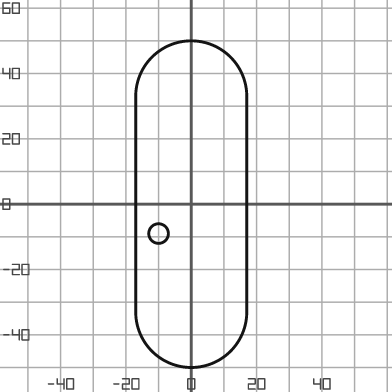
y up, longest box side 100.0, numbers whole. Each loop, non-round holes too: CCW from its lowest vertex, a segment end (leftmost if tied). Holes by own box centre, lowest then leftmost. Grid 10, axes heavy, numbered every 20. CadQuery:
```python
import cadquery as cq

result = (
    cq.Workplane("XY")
    .moveTo(-17.0, -33.0)
    .threePointArc((0.0, -50.0), (17.0, -33.0))
    .lineTo(17.0, 33.0)
    .threePointArc((0.0, 50.0), (-17.0, 33.0))
    .close()
    .moveTo(-10.0, -9.0)
    .circle(3.0)
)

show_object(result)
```